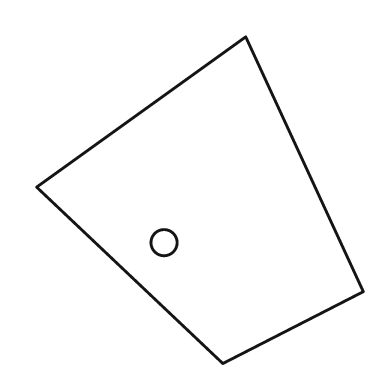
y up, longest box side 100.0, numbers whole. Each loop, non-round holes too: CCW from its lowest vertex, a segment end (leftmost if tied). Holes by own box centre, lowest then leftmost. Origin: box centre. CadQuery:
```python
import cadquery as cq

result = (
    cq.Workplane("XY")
    .moveTo(7.0, -50.0)
    .lineTo(50.0, -28.0)
    .lineTo(14.0, 50.0)
    .lineTo(-50.0, 4.0)
    .close()
    .moveTo(-11.0, -13.0)
    .circle(4.0)
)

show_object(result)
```